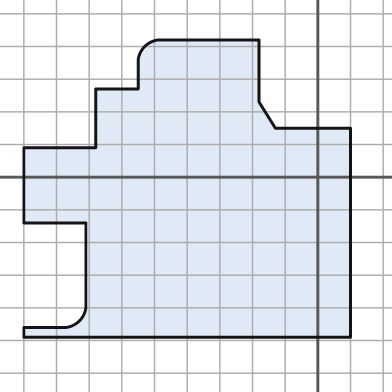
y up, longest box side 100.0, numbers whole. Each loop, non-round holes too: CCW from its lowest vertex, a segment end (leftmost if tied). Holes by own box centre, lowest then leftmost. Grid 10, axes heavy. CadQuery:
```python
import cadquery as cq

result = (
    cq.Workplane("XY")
    .moveTo(-90.0, -49.0)
    .lineTo(10.0, -49.0)
    .lineTo(10.0, 15.0)
    .lineTo(-13.0, 15.0)
    .lineTo(-18.0, 23.0)
    .lineTo(-18.0, 42.0)
    .lineTo(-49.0, 42.0)
    .threePointArc((-53.0, 40.0), (-55.0, 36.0))
    .lineTo(-55.0, 27.0)
    .lineTo(-68.0, 27.0)
    .lineTo(-68.0, 9.0)
    .lineTo(-90.0, 9.0)
    .lineTo(-90.0, -14.0)
    .lineTo(-71.0, -14.0)
    .lineTo(-71.0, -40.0)
    .threePointArc((-73.0, -44.0), (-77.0, -46.0))
    .lineTo(-90.0, -46.0)
    .close()
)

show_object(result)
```